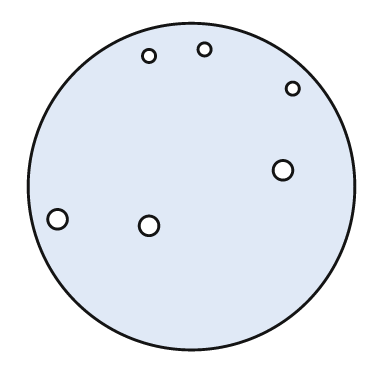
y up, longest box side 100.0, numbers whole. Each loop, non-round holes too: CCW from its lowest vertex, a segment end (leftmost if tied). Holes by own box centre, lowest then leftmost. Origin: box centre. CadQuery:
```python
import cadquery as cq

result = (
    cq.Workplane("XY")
    .moveTo(0.0, 0.0)
    .circle(50.0)
    .moveTo(-13.0, -12.0)
    .circle(3.0)
    .moveTo(-41.0, -10.0)
    .circle(3.0)
    .moveTo(28.0, 5.0)
    .circle(3.0)
    .moveTo(31.0, 30.0)
    .circle(2.0)
    .moveTo(-13.0, 40.0)
    .circle(2.0)
    .moveTo(4.0, 42.0)
    .circle(2.0)
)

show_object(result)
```